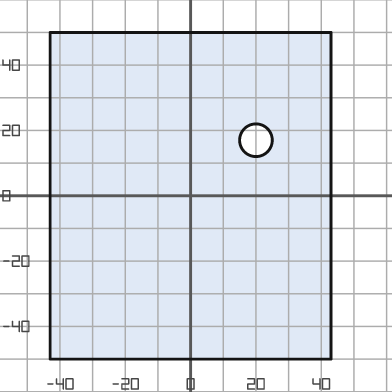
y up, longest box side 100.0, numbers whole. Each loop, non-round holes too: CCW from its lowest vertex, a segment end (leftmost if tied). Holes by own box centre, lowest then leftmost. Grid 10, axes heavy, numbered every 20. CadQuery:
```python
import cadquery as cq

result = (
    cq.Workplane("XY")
    .moveTo(-43.0, -50.0)
    .lineTo(43.0, -50.0)
    .lineTo(43.0, 50.0)
    .lineTo(-43.0, 50.0)
    .close()
    .moveTo(20.0, 17.0)
    .circle(5.0)
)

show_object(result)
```